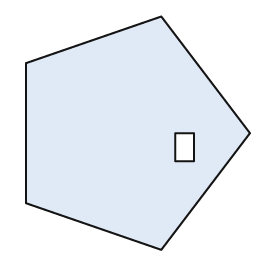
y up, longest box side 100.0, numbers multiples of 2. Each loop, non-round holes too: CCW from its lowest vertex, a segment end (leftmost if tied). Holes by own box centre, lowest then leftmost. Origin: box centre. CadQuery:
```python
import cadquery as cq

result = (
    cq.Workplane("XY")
    .moveTo(10.0, -50.0)
    .lineTo(48.0, 0.0)
    .lineTo(10.0, 50.0)
    .lineTo(-48.0, 30.0)
    .lineTo(-48.0, -30.0)
    .close()
    .moveTo(16.0, -12.0)
    .lineTo(24.0, -12.0)
    .lineTo(24.0, 0.0)
    .lineTo(16.0, 0.0)
    .close()
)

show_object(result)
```